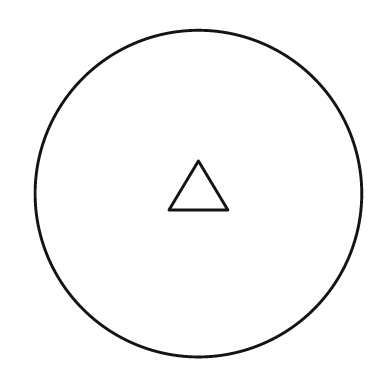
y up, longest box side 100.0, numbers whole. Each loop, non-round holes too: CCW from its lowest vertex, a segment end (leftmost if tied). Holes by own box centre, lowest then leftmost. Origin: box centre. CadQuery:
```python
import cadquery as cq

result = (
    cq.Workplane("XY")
    .moveTo(0.0, 0.0)
    .circle(50.0)
    .moveTo(-9.0, -5.0)
    .lineTo(9.0, -5.0)
    .lineTo(0.0, 10.0)
    .close()
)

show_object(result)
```